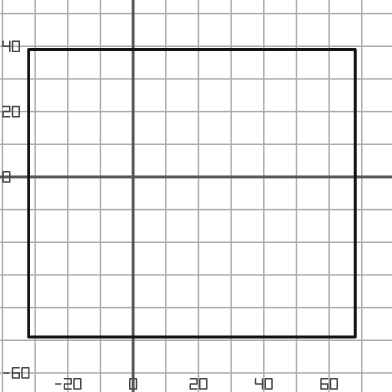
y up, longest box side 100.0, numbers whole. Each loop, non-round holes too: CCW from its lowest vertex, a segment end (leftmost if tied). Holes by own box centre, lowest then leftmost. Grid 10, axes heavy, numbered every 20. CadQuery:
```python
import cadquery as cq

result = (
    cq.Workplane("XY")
    .moveTo(-32.0, -49.0)
    .lineTo(68.0, -49.0)
    .lineTo(68.0, 39.0)
    .lineTo(-32.0, 39.0)
    .close()
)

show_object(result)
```